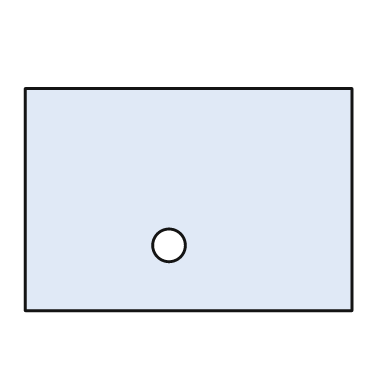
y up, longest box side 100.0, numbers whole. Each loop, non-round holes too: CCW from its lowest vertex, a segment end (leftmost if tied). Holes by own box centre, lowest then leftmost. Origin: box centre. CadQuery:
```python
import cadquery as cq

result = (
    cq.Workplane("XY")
    .moveTo(-50.0, -34.0)
    .lineTo(50.0, -34.0)
    .lineTo(50.0, 34.0)
    .lineTo(-50.0, 34.0)
    .close()
    .moveTo(-6.0, -14.0)
    .circle(5.0)
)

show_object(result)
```